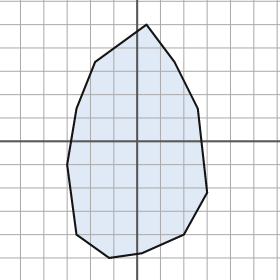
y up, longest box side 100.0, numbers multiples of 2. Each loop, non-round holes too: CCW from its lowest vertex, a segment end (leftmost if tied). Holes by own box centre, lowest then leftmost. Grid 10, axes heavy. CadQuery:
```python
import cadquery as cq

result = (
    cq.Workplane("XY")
    .moveTo(-12.0, -50.0)
    .lineTo(2.0, -48.0)
    .lineTo(20.0, -40.0)
    .lineTo(30.0, -22.0)
    .lineTo(26.0, 14.0)
    .lineTo(16.0, 34.0)
    .lineTo(4.0, 50.0)
    .lineTo(-18.0, 34.0)
    .lineTo(-26.0, 14.0)
    .lineTo(-30.0, -10.0)
    .lineTo(-26.0, -40.0)
    .close()
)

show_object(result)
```